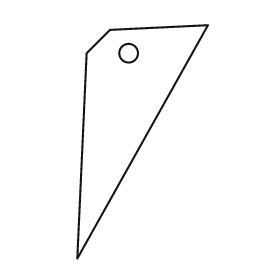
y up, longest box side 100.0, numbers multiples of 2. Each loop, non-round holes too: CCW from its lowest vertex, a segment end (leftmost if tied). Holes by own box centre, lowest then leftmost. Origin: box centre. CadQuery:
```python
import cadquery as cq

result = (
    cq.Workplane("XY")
    .moveTo(-28.0, -50.0)
    .lineTo(28.0, 50.0)
    .lineTo(-14.0, 48.0)
    .lineTo(-24.0, 38.0)
    .close()
    .moveTo(-6.0, 38.0)
    .circle(4.0)
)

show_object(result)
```